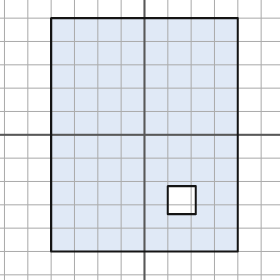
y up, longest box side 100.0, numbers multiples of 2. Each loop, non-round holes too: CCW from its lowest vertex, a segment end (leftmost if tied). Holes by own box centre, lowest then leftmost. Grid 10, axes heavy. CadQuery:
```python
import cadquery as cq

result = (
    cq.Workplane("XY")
    .moveTo(-40.0, -50.0)
    .lineTo(40.0, -50.0)
    .lineTo(40.0, 50.0)
    .lineTo(-40.0, 50.0)
    .close()
    .moveTo(10.0, -34.0)
    .lineTo(22.0, -34.0)
    .lineTo(22.0, -22.0)
    .lineTo(10.0, -22.0)
    .close()
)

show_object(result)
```